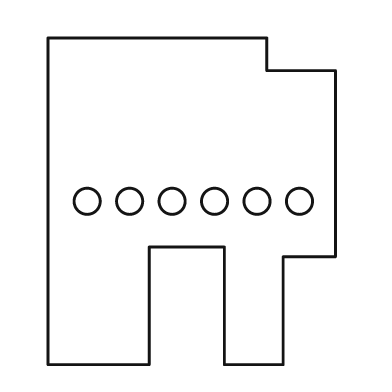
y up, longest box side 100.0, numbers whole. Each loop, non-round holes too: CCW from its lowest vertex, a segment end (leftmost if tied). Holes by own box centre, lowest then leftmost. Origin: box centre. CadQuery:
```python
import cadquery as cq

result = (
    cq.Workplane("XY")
    .moveTo(-44.0, -50.0)
    .lineTo(-13.0, -50.0)
    .lineTo(-13.0, -14.0)
    .lineTo(10.0, -14.0)
    .lineTo(10.0, -50.0)
    .lineTo(28.0, -50.0)
    .lineTo(28.0, -17.0)
    .lineTo(44.0, -17.0)
    .lineTo(44.0, 40.0)
    .lineTo(23.0, 40.0)
    .lineTo(23.0, 50.0)
    .lineTo(-44.0, 50.0)
    .close()
    .moveTo(-32.0, 0.0)
    .circle(4.0)
    .moveTo(-19.0, 0.0)
    .circle(4.0)
    .moveTo(-6.0, 0.0)
    .circle(4.0)
    .moveTo(7.0, 0.0)
    .circle(4.0)
    .moveTo(20.0, 0.0)
    .circle(4.0)
    .moveTo(33.0, 0.0)
    .circle(4.0)
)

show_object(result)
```